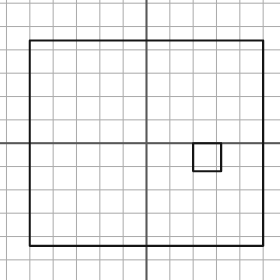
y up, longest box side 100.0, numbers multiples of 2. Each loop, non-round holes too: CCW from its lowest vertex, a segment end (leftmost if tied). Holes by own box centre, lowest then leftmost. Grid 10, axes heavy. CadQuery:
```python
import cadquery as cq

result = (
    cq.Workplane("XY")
    .moveTo(-50.0, -44.0)
    .lineTo(50.0, -44.0)
    .lineTo(50.0, 44.0)
    .lineTo(-50.0, 44.0)
    .close()
    .moveTo(20.0, -12.0)
    .lineTo(32.0, -12.0)
    .lineTo(32.0, 0.0)
    .lineTo(20.0, 0.0)
    .close()
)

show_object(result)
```